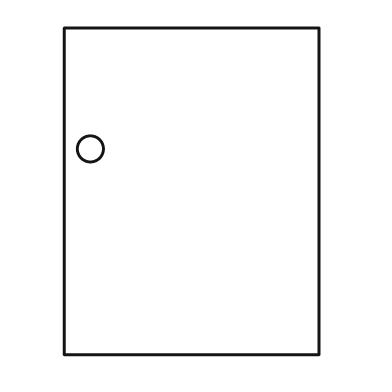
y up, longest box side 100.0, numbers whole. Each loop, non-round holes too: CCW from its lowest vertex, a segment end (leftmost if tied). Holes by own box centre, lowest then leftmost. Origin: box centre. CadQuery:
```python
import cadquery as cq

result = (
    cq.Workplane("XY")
    .moveTo(-39.0, -50.0)
    .lineTo(39.0, -50.0)
    .lineTo(39.0, 50.0)
    .lineTo(-39.0, 50.0)
    .close()
    .moveTo(-31.0, 13.0)
    .circle(4.0)
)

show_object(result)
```